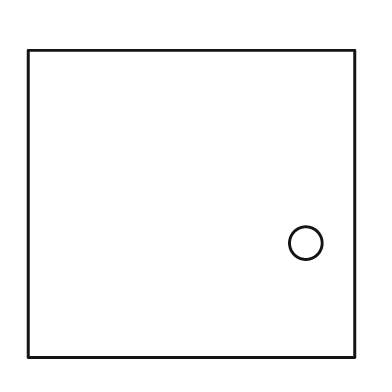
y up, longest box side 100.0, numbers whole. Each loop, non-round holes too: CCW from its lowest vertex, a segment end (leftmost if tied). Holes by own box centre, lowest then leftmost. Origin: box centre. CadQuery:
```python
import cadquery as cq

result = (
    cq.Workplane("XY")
    .moveTo(-50.0, -47.0)
    .lineTo(50.0, -47.0)
    .lineTo(50.0, 47.0)
    .lineTo(-50.0, 47.0)
    .close()
    .moveTo(35.0, -12.0)
    .circle(5.0)
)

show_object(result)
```